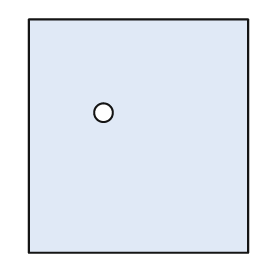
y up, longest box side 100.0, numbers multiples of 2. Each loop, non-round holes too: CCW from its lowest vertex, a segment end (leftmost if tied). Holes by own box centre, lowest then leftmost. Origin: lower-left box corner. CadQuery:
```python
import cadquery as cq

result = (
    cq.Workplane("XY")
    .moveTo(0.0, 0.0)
    .lineTo(94.0, 0.0)
    .lineTo(94.0, 100.0)
    .lineTo(0.0, 100.0)
    .close()
    .moveTo(32.0, 60.0)
    .circle(4.0)
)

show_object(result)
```